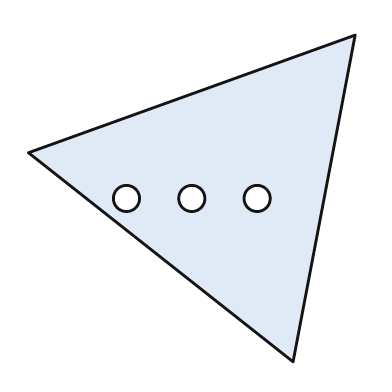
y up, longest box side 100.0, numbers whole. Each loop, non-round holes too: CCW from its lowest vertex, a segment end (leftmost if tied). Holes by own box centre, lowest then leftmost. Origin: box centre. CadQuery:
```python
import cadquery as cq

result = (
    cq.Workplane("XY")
    .moveTo(31.0, -50.0)
    .lineTo(50.0, 50.0)
    .lineTo(-50.0, 14.0)
    .close()
    .moveTo(-20.0, 0.0)
    .circle(4.0)
    .moveTo(0.0, 0.0)
    .circle(4.0)
    .moveTo(20.0, 0.0)
    .circle(4.0)
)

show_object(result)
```